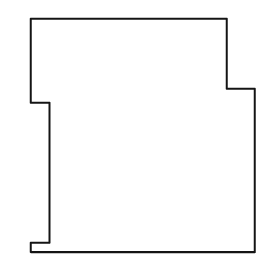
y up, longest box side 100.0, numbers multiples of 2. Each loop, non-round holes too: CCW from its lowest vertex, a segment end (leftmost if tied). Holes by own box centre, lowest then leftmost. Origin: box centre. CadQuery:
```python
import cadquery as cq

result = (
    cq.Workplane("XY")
    .moveTo(-48.0, -50.0)
    .lineTo(48.0, -50.0)
    .lineTo(48.0, 20.0)
    .lineTo(36.0, 20.0)
    .lineTo(36.0, 50.0)
    .lineTo(-48.0, 50.0)
    .lineTo(-48.0, 14.0)
    .lineTo(-40.0, 14.0)
    .lineTo(-40.0, -46.0)
    .lineTo(-48.0, -46.0)
    .close()
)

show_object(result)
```